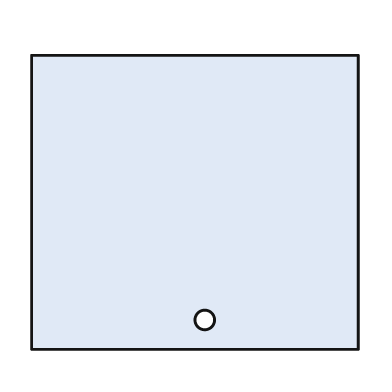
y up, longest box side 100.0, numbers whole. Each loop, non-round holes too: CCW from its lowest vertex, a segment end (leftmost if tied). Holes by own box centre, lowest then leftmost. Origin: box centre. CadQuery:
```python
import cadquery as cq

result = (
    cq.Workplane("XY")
    .moveTo(-50.0, -45.0)
    .lineTo(50.0, -45.0)
    .lineTo(50.0, 45.0)
    .lineTo(-50.0, 45.0)
    .close()
    .moveTo(3.0, -36.0)
    .circle(3.0)
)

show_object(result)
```